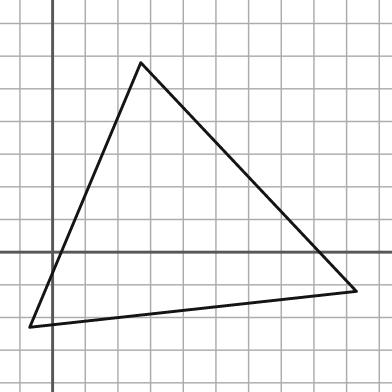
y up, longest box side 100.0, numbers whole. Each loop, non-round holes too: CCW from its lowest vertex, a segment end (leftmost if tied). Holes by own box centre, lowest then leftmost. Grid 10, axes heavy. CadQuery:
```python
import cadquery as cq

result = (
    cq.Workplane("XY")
    .moveTo(-7.0, -23.0)
    .lineTo(93.0, -12.0)
    .lineTo(27.0, 58.0)
    .close()
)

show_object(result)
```